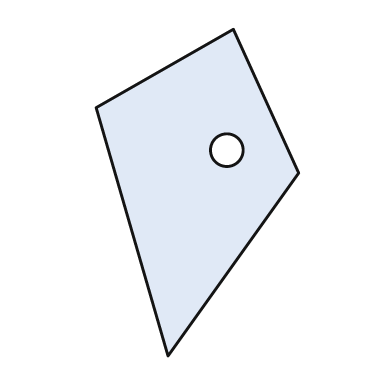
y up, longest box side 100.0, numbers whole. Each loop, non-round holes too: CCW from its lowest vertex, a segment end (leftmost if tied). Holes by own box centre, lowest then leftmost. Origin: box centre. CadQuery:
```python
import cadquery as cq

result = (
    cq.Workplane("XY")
    .moveTo(-9.0, -50.0)
    .lineTo(31.0, 6.0)
    .lineTo(11.0, 50.0)
    .lineTo(-31.0, 26.0)
    .close()
    .moveTo(9.0, 13.0)
    .circle(5.0)
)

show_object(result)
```